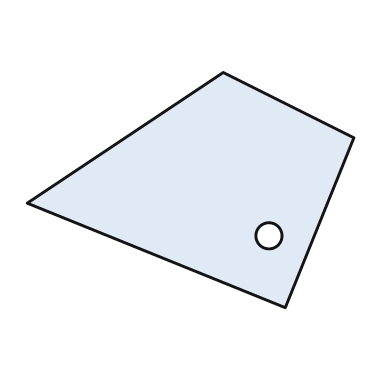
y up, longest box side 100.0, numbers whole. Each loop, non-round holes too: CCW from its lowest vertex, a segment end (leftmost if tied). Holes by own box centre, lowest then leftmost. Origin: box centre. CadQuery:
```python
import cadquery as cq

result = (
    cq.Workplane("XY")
    .moveTo(29.0, -36.0)
    .lineTo(50.0, 16.0)
    .lineTo(10.0, 36.0)
    .lineTo(-50.0, -4.0)
    .close()
    .moveTo(24.0, -14.0)
    .circle(4.0)
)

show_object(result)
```